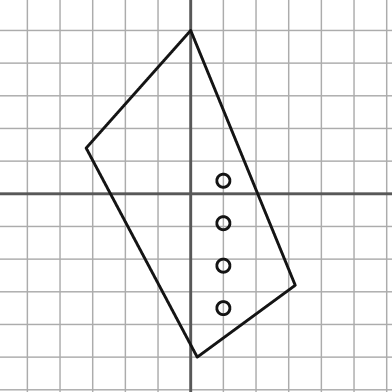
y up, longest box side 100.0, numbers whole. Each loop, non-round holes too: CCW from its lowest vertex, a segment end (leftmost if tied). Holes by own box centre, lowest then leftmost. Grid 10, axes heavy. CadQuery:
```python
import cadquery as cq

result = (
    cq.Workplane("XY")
    .moveTo(2.0, -50.0)
    .lineTo(32.0, -28.0)
    .lineTo(0.0, 50.0)
    .lineTo(-32.0, 14.0)
    .close()
    .moveTo(10.0, -35.0)
    .circle(2.0)
    .moveTo(10.0, -22.0)
    .circle(2.0)
    .moveTo(10.0, -9.0)
    .circle(2.0)
    .moveTo(10.0, 4.0)
    .circle(2.0)
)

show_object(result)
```